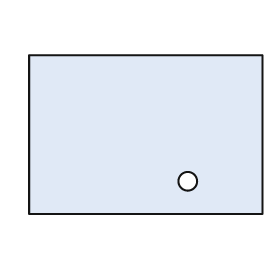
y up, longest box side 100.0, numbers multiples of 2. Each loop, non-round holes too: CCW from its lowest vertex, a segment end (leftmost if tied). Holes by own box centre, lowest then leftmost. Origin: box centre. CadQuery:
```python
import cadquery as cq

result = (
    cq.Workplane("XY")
    .moveTo(-50.0, -34.0)
    .lineTo(50.0, -34.0)
    .lineTo(50.0, 34.0)
    .lineTo(-50.0, 34.0)
    .close()
    .moveTo(18.0, -20.0)
    .circle(4.0)
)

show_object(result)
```